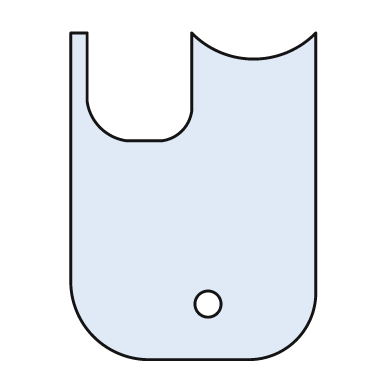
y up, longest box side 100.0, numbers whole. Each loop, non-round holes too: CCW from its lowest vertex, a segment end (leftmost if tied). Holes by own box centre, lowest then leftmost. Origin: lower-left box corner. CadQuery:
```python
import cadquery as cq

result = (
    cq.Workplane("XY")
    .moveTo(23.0, 0.0)
    .lineTo(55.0, 0.0)
    .threePointArc((69.0, 6.0), (75.0, 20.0))
    .lineTo(75.0, 100.0)
    .threePointArc((56.0, 92.0), (37.0, 100.0))
    .lineTo(37.0, 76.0)
    .threePointArc((34.0, 70.0), (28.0, 67.0))
    .lineTo(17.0, 67.0)
    .threePointArc((9.0, 71.0), (5.0, 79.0))
    .lineTo(5.0, 100.0)
    .lineTo(0.0, 100.0)
    .lineTo(0.0, 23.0)
    .threePointArc((7.0, 7.0), (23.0, 0.0))
    .close()
    .moveTo(42.0, 17.0)
    .circle(4.0)
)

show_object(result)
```